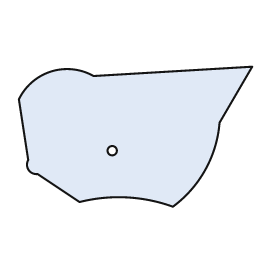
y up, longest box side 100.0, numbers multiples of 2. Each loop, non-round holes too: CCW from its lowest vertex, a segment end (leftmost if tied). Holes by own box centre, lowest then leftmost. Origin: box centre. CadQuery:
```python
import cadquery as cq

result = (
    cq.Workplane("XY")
    .moveTo(16.0, -30.0)
    .threePointArc((30.0, -14.0), (36.0, 6.0))
    .lineTo(50.0, 30.0)
    .lineTo(-18.0, 26.0)
    .threePointArc((-36.0, 28.0), (-50.0, 16.0))
    .lineTo(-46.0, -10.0)
    .threePointArc((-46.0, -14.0), (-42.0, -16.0))
    .lineTo(-24.0, -28.0)
    .threePointArc((-4.0, -26.0), (16.0, -30.0))
    .close()
    .moveTo(-10.0, -6.0)
    .circle(2.0)
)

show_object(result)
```